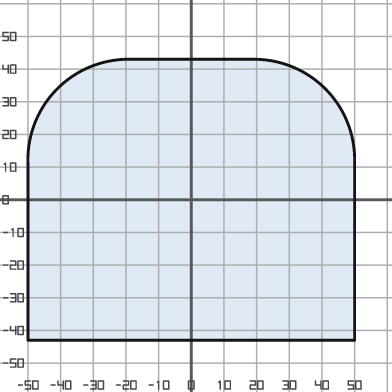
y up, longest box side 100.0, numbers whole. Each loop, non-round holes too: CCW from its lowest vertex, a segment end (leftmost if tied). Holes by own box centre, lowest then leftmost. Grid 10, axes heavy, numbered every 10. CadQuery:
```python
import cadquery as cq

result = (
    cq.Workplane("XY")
    .moveTo(-50.0, -43.0)
    .lineTo(50.0, -43.0)
    .lineTo(50.0, 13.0)
    .threePointArc((41.0, 34.0), (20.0, 43.0))
    .lineTo(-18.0, 43.0)
    .threePointArc((-41.0, 34.0), (-50.0, 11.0))
    .close()
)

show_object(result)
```